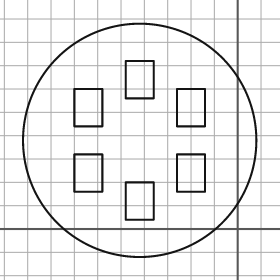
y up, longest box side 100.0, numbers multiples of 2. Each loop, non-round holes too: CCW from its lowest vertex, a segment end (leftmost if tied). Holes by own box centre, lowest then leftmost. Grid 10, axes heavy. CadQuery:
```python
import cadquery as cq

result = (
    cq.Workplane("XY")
    .moveTo(-42.0, 38.0)
    .circle(50.0)
    .moveTo(-48.0, 4.0)
    .lineTo(-36.0, 4.0)
    .lineTo(-36.0, 20.0)
    .lineTo(-48.0, 20.0)
    .close()
    .moveTo(-70.0, 16.0)
    .lineTo(-58.0, 16.0)
    .lineTo(-58.0, 32.0)
    .lineTo(-70.0, 32.0)
    .close()
    .moveTo(-26.0, 16.0)
    .lineTo(-14.0, 16.0)
    .lineTo(-14.0, 32.0)
    .lineTo(-26.0, 32.0)
    .close()
    .moveTo(-70.0, 44.0)
    .lineTo(-58.0, 44.0)
    .lineTo(-58.0, 60.0)
    .lineTo(-70.0, 60.0)
    .close()
    .moveTo(-26.0, 44.0)
    .lineTo(-14.0, 44.0)
    .lineTo(-14.0, 60.0)
    .lineTo(-26.0, 60.0)
    .close()
    .moveTo(-48.0, 56.0)
    .lineTo(-36.0, 56.0)
    .lineTo(-36.0, 72.0)
    .lineTo(-48.0, 72.0)
    .close()
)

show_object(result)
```